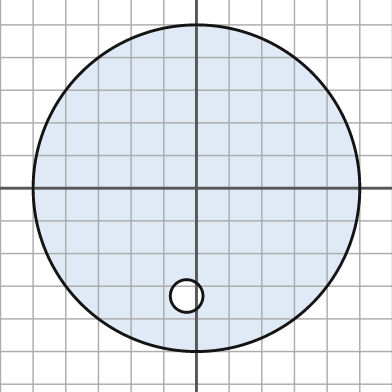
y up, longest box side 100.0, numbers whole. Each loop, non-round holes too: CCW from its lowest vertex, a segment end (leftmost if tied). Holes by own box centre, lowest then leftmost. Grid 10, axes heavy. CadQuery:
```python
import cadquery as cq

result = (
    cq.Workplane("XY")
    .moveTo(0.0, 0.0)
    .circle(50.0)
    .moveTo(-3.0, -33.0)
    .circle(5.0)
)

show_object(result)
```